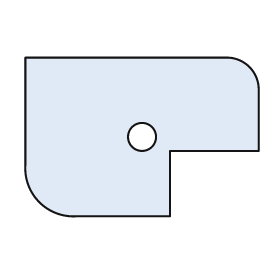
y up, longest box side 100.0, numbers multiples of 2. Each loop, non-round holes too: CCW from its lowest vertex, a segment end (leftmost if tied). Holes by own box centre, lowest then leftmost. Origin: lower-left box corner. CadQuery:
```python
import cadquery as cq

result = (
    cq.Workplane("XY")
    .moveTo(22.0, 0.0)
    .lineTo(62.0, 0.0)
    .lineTo(62.0, 28.0)
    .lineTo(100.0, 28.0)
    .lineTo(100.0, 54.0)
    .threePointArc((96.0, 64.0), (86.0, 68.0))
    .lineTo(0.0, 68.0)
    .lineTo(0.0, 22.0)
    .threePointArc((6.0, 6.0), (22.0, 0.0))
    .close()
    .moveTo(50.0, 34.0)
    .circle(6.0)
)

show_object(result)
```